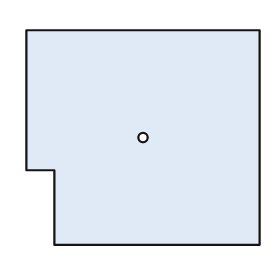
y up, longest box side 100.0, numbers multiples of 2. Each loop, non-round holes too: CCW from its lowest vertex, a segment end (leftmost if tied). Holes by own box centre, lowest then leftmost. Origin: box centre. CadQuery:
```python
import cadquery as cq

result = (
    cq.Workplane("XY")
    .moveTo(-38.0, -46.0)
    .lineTo(50.0, -46.0)
    .lineTo(50.0, 46.0)
    .lineTo(-50.0, 46.0)
    .lineTo(-50.0, -14.0)
    .lineTo(-38.0, -14.0)
    .close()
    .moveTo(0.0, 0.0)
    .circle(2.0)
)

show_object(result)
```